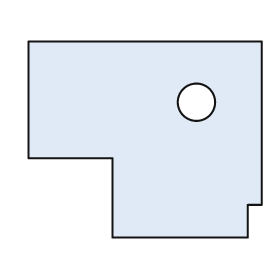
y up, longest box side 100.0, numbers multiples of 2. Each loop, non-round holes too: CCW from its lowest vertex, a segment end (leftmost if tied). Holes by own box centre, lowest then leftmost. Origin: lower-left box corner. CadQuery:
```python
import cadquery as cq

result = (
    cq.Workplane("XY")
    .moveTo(36.0, 0.0)
    .lineTo(94.0, 0.0)
    .lineTo(94.0, 14.0)
    .lineTo(100.0, 14.0)
    .lineTo(100.0, 84.0)
    .lineTo(0.0, 84.0)
    .lineTo(0.0, 34.0)
    .lineTo(36.0, 34.0)
    .close()
    .moveTo(72.0, 58.0)
    .circle(8.0)
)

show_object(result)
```